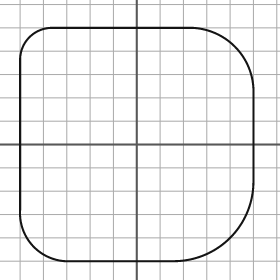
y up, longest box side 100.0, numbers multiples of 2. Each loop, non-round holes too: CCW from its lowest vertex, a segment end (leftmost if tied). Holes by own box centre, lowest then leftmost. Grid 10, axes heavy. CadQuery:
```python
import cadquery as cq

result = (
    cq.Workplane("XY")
    .moveTo(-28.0, -50.0)
    .lineTo(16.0, -50.0)
    .threePointArc((40.0, -40.0), (50.0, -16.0))
    .lineTo(50.0, 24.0)
    .threePointArc((42.0, 42.0), (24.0, 50.0))
    .lineTo(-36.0, 50.0)
    .threePointArc((-46.0, 46.0), (-50.0, 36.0))
    .lineTo(-50.0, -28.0)
    .threePointArc((-44.0, -44.0), (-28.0, -50.0))
    .close()
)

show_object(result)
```